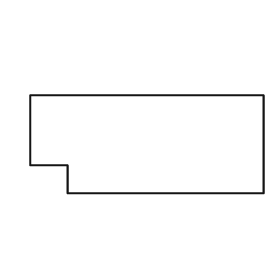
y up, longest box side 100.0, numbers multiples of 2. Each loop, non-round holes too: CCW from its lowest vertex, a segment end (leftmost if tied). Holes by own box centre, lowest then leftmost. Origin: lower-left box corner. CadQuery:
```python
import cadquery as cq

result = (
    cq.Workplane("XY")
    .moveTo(16.0, 0.0)
    .lineTo(100.0, 0.0)
    .lineTo(100.0, 42.0)
    .lineTo(0.0, 42.0)
    .lineTo(0.0, 12.0)
    .lineTo(16.0, 12.0)
    .close()
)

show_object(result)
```